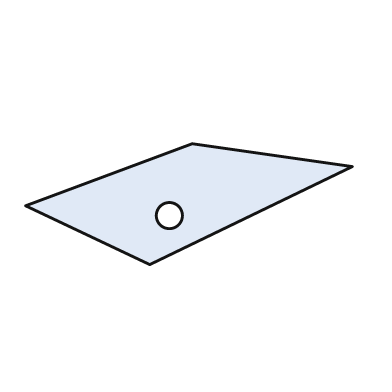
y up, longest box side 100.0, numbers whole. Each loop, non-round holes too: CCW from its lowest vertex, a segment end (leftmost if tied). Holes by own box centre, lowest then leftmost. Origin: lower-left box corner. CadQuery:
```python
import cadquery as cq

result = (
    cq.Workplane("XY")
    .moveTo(38.0, 0.0)
    .lineTo(100.0, 30.0)
    .lineTo(51.0, 37.0)
    .lineTo(0.0, 18.0)
    .close()
    .moveTo(44.0, 15.0)
    .circle(4.0)
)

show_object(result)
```